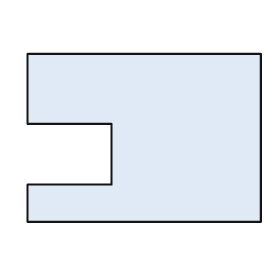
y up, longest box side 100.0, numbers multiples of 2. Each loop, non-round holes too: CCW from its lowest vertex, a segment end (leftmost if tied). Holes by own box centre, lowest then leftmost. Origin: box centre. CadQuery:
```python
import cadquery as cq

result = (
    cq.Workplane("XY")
    .moveTo(-50.0, -36.0)
    .lineTo(50.0, -36.0)
    .lineTo(50.0, 36.0)
    .lineTo(-50.0, 36.0)
    .lineTo(-50.0, 6.0)
    .lineTo(-14.0, 6.0)
    .lineTo(-14.0, -20.0)
    .lineTo(-50.0, -20.0)
    .close()
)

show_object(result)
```